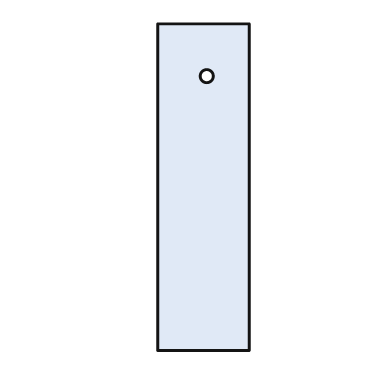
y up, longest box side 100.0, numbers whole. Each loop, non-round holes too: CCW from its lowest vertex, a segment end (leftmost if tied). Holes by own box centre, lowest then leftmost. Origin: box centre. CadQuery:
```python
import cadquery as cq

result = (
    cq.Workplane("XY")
    .moveTo(-14.0, -50.0)
    .lineTo(14.0, -50.0)
    .lineTo(14.0, 50.0)
    .lineTo(-14.0, 50.0)
    .close()
    .moveTo(1.0, 34.0)
    .circle(2.0)
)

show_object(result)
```